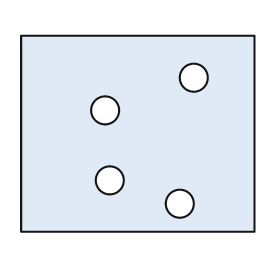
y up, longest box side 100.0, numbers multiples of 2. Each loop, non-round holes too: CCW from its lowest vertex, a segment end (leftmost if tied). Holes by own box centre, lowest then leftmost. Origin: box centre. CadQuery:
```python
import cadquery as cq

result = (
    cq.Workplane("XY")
    .moveTo(-50.0, -42.0)
    .lineTo(50.0, -42.0)
    .lineTo(50.0, 42.0)
    .lineTo(-50.0, 42.0)
    .close()
    .moveTo(18.0, -30.0)
    .circle(6.0)
    .moveTo(-12.0, -20.0)
    .circle(6.0)
    .moveTo(-14.0, 10.0)
    .circle(6.0)
    .moveTo(24.0, 24.0)
    .circle(6.0)
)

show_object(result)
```